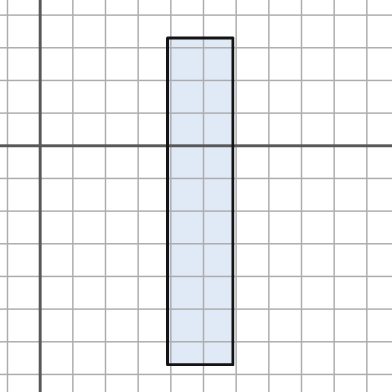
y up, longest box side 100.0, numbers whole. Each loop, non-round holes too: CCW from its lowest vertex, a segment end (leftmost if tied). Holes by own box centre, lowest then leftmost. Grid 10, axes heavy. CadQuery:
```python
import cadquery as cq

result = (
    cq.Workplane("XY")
    .moveTo(39.0, -67.0)
    .lineTo(59.0, -67.0)
    .lineTo(59.0, 33.0)
    .lineTo(39.0, 33.0)
    .close()
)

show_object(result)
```